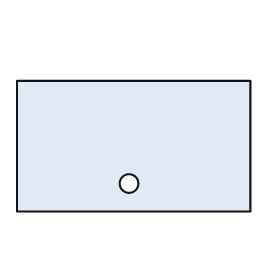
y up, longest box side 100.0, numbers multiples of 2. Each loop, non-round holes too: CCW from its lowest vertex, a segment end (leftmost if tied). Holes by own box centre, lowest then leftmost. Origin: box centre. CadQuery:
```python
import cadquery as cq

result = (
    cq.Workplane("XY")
    .moveTo(-50.0, -28.0)
    .lineTo(50.0, -28.0)
    .lineTo(50.0, 28.0)
    .lineTo(-50.0, 28.0)
    .close()
    .moveTo(-2.0, -16.0)
    .circle(4.0)
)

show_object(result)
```